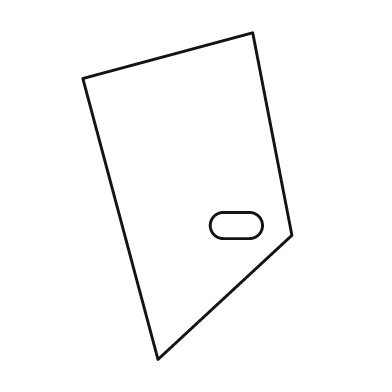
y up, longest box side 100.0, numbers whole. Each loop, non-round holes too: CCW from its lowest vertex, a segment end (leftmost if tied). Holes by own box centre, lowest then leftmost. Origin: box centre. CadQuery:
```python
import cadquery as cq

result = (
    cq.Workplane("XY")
    .moveTo(-9.0, -50.0)
    .lineTo(32.0, -12.0)
    .lineTo(20.0, 50.0)
    .lineTo(-32.0, 36.0)
    .close()
    .moveTo(11.0, -13.0)
    .lineTo(19.0, -13.0)
    .threePointArc((23.0, -9.0), (19.0, -5.0))
    .lineTo(11.0, -5.0)
    .threePointArc((7.0, -9.0), (11.0, -13.0))
    .close()
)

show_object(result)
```